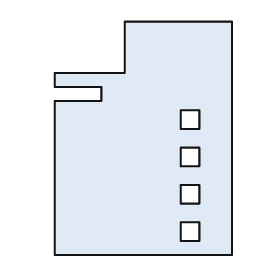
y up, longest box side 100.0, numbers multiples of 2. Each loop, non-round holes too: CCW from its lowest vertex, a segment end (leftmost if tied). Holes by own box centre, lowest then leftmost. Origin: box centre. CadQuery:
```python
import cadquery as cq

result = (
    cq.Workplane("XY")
    .moveTo(-38.0, -50.0)
    .lineTo(38.0, -50.0)
    .lineTo(38.0, 50.0)
    .lineTo(-8.0, 50.0)
    .lineTo(-8.0, 28.0)
    .lineTo(-38.0, 28.0)
    .lineTo(-38.0, 22.0)
    .lineTo(-18.0, 22.0)
    .lineTo(-18.0, 16.0)
    .lineTo(-38.0, 16.0)
    .close()
    .moveTo(16.0, -44.0)
    .lineTo(24.0, -44.0)
    .lineTo(24.0, -36.0)
    .lineTo(16.0, -36.0)
    .close()
    .moveTo(16.0, -28.0)
    .lineTo(24.0, -28.0)
    .lineTo(24.0, -20.0)
    .lineTo(16.0, -20.0)
    .close()
    .moveTo(16.0, -12.0)
    .lineTo(24.0, -12.0)
    .lineTo(24.0, -4.0)
    .lineTo(16.0, -4.0)
    .close()
    .moveTo(16.0, 4.0)
    .lineTo(24.0, 4.0)
    .lineTo(24.0, 12.0)
    .lineTo(16.0, 12.0)
    .close()
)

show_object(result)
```